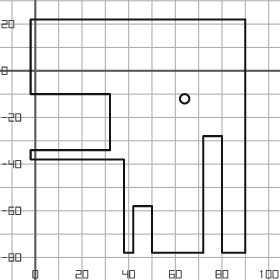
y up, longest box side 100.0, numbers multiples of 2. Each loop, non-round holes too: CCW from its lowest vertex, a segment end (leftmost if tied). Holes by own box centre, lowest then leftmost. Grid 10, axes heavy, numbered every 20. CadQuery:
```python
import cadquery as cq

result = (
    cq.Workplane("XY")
    .moveTo(38.0, -78.0)
    .lineTo(42.0, -78.0)
    .lineTo(42.0, -58.0)
    .lineTo(50.0, -58.0)
    .lineTo(50.0, -78.0)
    .lineTo(72.0, -78.0)
    .lineTo(72.0, -28.0)
    .lineTo(80.0, -28.0)
    .lineTo(80.0, -78.0)
    .lineTo(90.0, -78.0)
    .lineTo(90.0, 22.0)
    .lineTo(-2.0, 22.0)
    .lineTo(-2.0, -10.0)
    .lineTo(32.0, -10.0)
    .lineTo(32.0, -34.0)
    .lineTo(-2.0, -34.0)
    .lineTo(-2.0, -38.0)
    .lineTo(38.0, -38.0)
    .close()
    .moveTo(64.0, -12.0)
    .circle(2.0)
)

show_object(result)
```